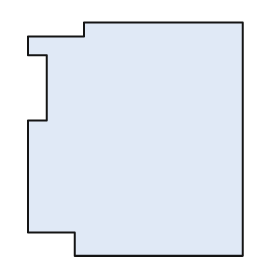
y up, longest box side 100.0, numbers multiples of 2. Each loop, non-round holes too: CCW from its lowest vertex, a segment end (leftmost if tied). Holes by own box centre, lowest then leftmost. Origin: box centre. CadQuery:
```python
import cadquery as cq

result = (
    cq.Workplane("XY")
    .moveTo(-26.0, -50.0)
    .lineTo(46.0, -50.0)
    .lineTo(46.0, 50.0)
    .lineTo(-22.0, 50.0)
    .lineTo(-22.0, 44.0)
    .lineTo(-46.0, 44.0)
    .lineTo(-46.0, 36.0)
    .lineTo(-38.0, 36.0)
    .lineTo(-38.0, 8.0)
    .lineTo(-46.0, 8.0)
    .lineTo(-46.0, -40.0)
    .lineTo(-26.0, -40.0)
    .close()
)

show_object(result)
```